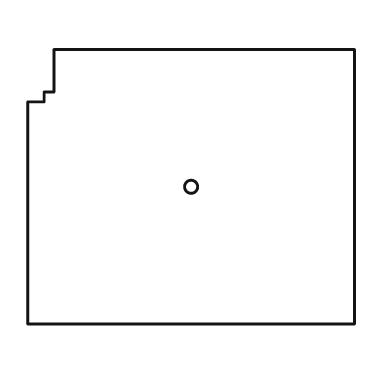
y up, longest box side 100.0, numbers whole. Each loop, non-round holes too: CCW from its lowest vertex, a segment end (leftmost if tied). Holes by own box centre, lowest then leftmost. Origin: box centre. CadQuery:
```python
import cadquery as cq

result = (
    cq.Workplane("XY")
    .moveTo(-50.0, -42.0)
    .lineTo(50.0, -42.0)
    .lineTo(50.0, 42.0)
    .lineTo(-42.0, 42.0)
    .lineTo(-42.0, 29.0)
    .lineTo(-45.0, 29.0)
    .lineTo(-45.0, 26.0)
    .lineTo(-50.0, 26.0)
    .close()
    .moveTo(0.0, 0.0)
    .circle(2.0)
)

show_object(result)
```